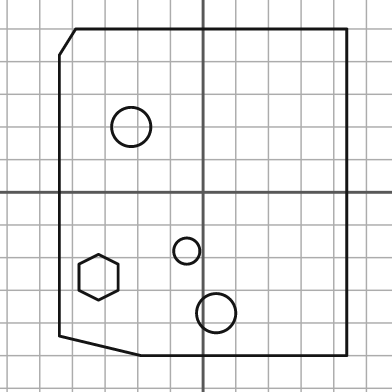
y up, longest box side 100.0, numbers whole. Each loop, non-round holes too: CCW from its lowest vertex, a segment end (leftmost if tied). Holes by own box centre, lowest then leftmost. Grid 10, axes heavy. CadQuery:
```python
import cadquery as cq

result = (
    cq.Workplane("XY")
    .moveTo(-19.0, -50.0)
    .lineTo(44.0, -50.0)
    .lineTo(44.0, 50.0)
    .lineTo(-39.0, 50.0)
    .lineTo(-44.0, 42.0)
    .lineTo(-44.0, -44.0)
    .close()
    .moveTo(4.0, -37.0)
    .circle(6.0)
    .moveTo(-32.0, -33.0)
    .lineTo(-26.0, -30.0)
    .lineTo(-26.0, -22.0)
    .lineTo(-32.0, -19.0)
    .lineTo(-38.0, -22.0)
    .lineTo(-38.0, -30.0)
    .close()
    .moveTo(-5.0, -18.0)
    .circle(4.0)
    .moveTo(-22.0, 20.0)
    .circle(6.0)
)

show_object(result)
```